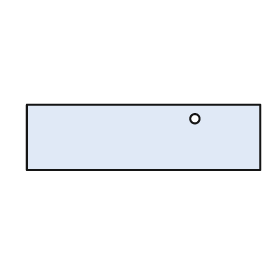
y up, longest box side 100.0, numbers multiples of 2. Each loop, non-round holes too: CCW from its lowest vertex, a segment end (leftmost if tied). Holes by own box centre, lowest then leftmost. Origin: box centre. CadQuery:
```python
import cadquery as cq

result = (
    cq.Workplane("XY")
    .moveTo(-50.0, -14.0)
    .lineTo(50.0, -14.0)
    .lineTo(50.0, 14.0)
    .lineTo(-50.0, 14.0)
    .close()
    .moveTo(22.0, 8.0)
    .circle(2.0)
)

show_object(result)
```